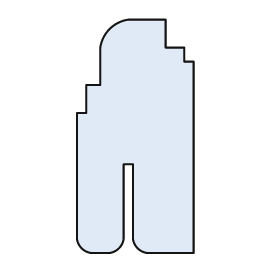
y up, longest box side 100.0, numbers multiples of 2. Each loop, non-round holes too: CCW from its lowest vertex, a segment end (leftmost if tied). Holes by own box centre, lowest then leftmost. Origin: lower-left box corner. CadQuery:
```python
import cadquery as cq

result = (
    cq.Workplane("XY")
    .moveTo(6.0, 0.0)
    .lineTo(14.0, 0.0)
    .threePointArc((18.0, 2.0), (20.0, 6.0))
    .lineTo(20.0, 38.0)
    .lineTo(24.0, 38.0)
    .lineTo(24.0, 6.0)
    .threePointArc((26.0, 2.0), (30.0, 0.0))
    .lineTo(50.0, 0.0)
    .lineTo(50.0, 82.0)
    .lineTo(46.0, 82.0)
    .lineTo(46.0, 88.0)
    .lineTo(38.0, 88.0)
    .lineTo(38.0, 100.0)
    .lineTo(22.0, 100.0)
    .threePointArc((14.0, 96.0), (10.0, 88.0))
    .lineTo(10.0, 72.0)
    .lineTo(4.0, 72.0)
    .lineTo(4.0, 60.0)
    .lineTo(0.0, 60.0)
    .lineTo(0.0, 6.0)
    .threePointArc((2.0, 2.0), (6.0, 0.0))
    .close()
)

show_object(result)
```